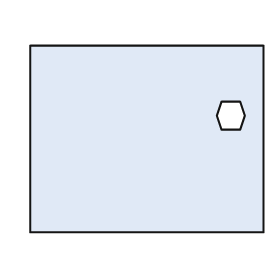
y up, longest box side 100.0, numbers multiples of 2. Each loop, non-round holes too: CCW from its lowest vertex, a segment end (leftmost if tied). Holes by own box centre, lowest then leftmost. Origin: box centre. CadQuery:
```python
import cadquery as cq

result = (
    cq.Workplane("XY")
    .moveTo(-50.0, -40.0)
    .lineTo(50.0, -40.0)
    .lineTo(50.0, 40.0)
    .lineTo(-50.0, 40.0)
    .close()
    .moveTo(32.0, 4.0)
    .lineTo(40.0, 4.0)
    .lineTo(42.0, 10.0)
    .lineTo(40.0, 16.0)
    .lineTo(32.0, 16.0)
    .lineTo(30.0, 10.0)
    .close()
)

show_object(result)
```